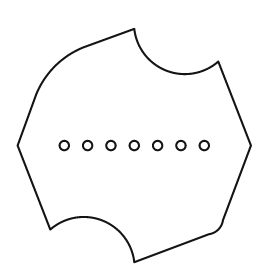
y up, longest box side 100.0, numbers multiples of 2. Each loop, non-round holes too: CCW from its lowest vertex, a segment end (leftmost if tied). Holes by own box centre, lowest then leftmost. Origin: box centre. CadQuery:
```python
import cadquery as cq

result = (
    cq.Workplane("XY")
    .moveTo(0.0, -50.0)
    .lineTo(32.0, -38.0)
    .threePointArc((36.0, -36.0), (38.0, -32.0))
    .lineTo(50.0, 0.0)
    .lineTo(36.0, 36.0)
    .threePointArc((14.0, 32.0), (0.0, 50.0))
    .lineTo(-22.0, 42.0)
    .threePointArc((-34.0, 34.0), (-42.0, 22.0))
    .lineTo(-50.0, 0.0)
    .lineTo(-36.0, -36.0)
    .threePointArc((-14.0, -32.0), (0.0, -50.0))
    .close()
    .moveTo(-30.0, 0.0)
    .circle(2.0)
    .moveTo(-20.0, 0.0)
    .circle(2.0)
    .moveTo(-10.0, 0.0)
    .circle(2.0)
    .moveTo(0.0, 0.0)
    .circle(2.0)
    .moveTo(10.0, 0.0)
    .circle(2.0)
    .moveTo(20.0, 0.0)
    .circle(2.0)
    .moveTo(30.0, 0.0)
    .circle(2.0)
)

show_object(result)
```